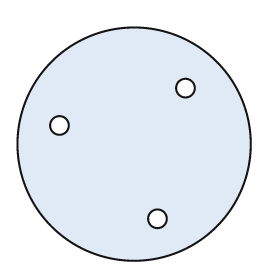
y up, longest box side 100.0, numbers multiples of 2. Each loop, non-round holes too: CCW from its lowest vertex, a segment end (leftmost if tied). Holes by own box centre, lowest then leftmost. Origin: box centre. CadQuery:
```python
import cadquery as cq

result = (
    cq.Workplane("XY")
    .moveTo(0.0, 0.0)
    .circle(50.0)
    .moveTo(10.0, -32.0)
    .circle(4.0)
    .moveTo(-32.0, 8.0)
    .circle(4.0)
    .moveTo(22.0, 24.0)
    .circle(4.0)
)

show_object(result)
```